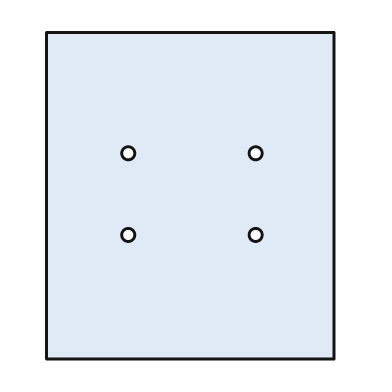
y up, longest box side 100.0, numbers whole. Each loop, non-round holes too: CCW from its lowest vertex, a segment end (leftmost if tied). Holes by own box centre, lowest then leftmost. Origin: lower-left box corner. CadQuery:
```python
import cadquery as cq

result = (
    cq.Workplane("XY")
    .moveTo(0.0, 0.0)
    .lineTo(88.0, 0.0)
    .lineTo(88.0, 100.0)
    .lineTo(0.0, 100.0)
    .close()
    .moveTo(25.0, 38.0)
    .circle(2.0)
    .moveTo(64.0, 38.0)
    .circle(2.0)
    .moveTo(25.0, 63.0)
    .circle(2.0)
    .moveTo(64.0, 63.0)
    .circle(2.0)
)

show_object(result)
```